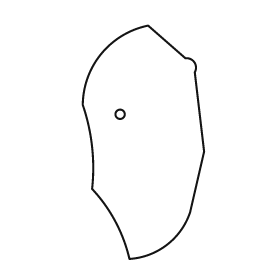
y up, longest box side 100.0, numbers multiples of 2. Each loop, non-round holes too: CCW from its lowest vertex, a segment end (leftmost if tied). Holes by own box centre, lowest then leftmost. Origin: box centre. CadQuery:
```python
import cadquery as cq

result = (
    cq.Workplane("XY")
    .moveTo(-6.0, -50.0)
    .threePointArc((10.0, -44.0), (20.0, -30.0))
    .lineTo(26.0, -4.0)
    .lineTo(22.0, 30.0)
    .threePointArc((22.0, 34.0), (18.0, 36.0))
    .lineTo(2.0, 50.0)
    .threePointArc((-18.0, 38.0), (-26.0, 16.0))
    .threePointArc((-22.0, -2.0), (-22.0, -20.0))
    .threePointArc((-12.0, -34.0), (-6.0, -50.0))
    .close()
    .moveTo(-10.0, 12.0)
    .circle(2.0)
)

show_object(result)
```